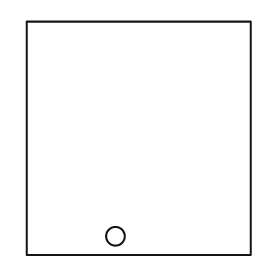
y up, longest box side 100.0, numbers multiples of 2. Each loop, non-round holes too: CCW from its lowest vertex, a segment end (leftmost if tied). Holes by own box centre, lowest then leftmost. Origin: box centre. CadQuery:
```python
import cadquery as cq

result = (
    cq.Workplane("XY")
    .moveTo(-48.0, -50.0)
    .lineTo(48.0, -50.0)
    .lineTo(48.0, 50.0)
    .lineTo(-48.0, 50.0)
    .close()
    .moveTo(-10.0, -42.0)
    .circle(4.0)
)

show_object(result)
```